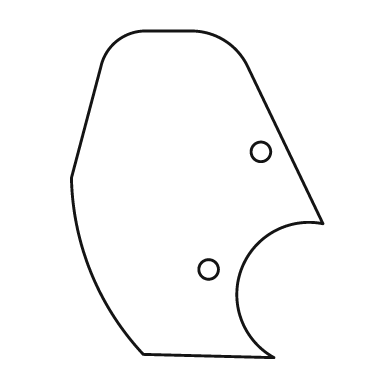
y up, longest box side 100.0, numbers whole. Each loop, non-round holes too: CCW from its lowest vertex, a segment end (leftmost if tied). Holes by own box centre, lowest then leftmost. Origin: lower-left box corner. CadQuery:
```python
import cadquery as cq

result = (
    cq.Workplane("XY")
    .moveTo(62.0, 0.0)
    .threePointArc((52.0, 27.0), (77.0, 41.0))
    .lineTo(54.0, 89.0)
    .threePointArc((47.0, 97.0), (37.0, 100.0))
    .lineTo(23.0, 100.0)
    .threePointArc((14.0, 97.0), (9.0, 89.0))
    .lineTo(0.0, 55.0)
    .threePointArc((6.0, 26.0), (22.0, 1.0))
    .close()
    .moveTo(42.0, 27.0)
    .circle(3.0)
    .moveTo(58.0, 63.0)
    .circle(3.0)
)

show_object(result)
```